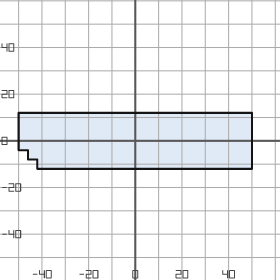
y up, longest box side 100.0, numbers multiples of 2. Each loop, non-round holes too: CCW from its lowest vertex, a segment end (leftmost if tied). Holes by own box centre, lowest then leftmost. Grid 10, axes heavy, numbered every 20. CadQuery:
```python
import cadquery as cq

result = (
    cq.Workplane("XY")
    .moveTo(-42.0, -12.0)
    .lineTo(50.0, -12.0)
    .lineTo(50.0, 12.0)
    .lineTo(-50.0, 12.0)
    .lineTo(-50.0, -4.0)
    .lineTo(-46.0, -4.0)
    .lineTo(-46.0, -8.0)
    .lineTo(-42.0, -8.0)
    .close()
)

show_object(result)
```